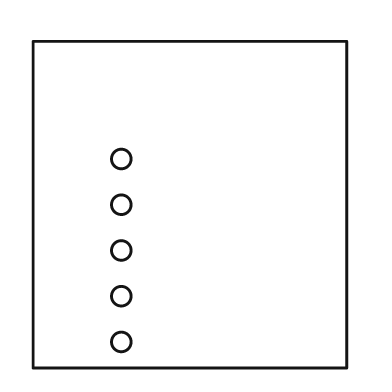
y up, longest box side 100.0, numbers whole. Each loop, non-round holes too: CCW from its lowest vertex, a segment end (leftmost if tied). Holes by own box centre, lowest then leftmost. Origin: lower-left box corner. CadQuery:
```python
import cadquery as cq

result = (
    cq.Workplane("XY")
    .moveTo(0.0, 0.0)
    .lineTo(96.0, 0.0)
    .lineTo(96.0, 100.0)
    .lineTo(0.0, 100.0)
    .close()
    .moveTo(27.0, 8.0)
    .circle(3.0)
    .moveTo(27.0, 22.0)
    .circle(3.0)
    .moveTo(27.0, 36.0)
    .circle(3.0)
    .moveTo(27.0, 50.0)
    .circle(3.0)
    .moveTo(27.0, 64.0)
    .circle(3.0)
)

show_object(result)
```